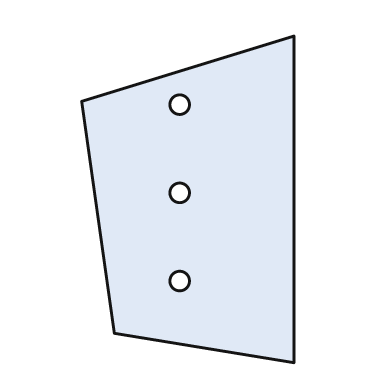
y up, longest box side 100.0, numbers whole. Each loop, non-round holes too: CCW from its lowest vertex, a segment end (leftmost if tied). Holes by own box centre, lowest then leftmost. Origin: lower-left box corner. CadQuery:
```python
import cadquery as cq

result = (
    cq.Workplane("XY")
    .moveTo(65.0, 0.0)
    .lineTo(65.0, 100.0)
    .lineTo(0.0, 80.0)
    .lineTo(10.0, 9.0)
    .close()
    .moveTo(30.0, 25.0)
    .circle(3.0)
    .moveTo(30.0, 52.0)
    .circle(3.0)
    .moveTo(30.0, 79.0)
    .circle(3.0)
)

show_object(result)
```